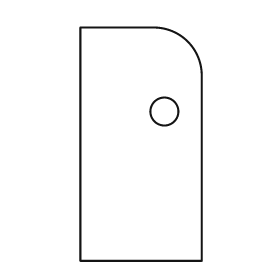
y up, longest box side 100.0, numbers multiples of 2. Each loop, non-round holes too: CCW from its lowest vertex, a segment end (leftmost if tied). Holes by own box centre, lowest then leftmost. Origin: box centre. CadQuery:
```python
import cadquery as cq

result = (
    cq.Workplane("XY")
    .moveTo(-26.0, -50.0)
    .lineTo(26.0, -50.0)
    .lineTo(26.0, 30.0)
    .threePointArc((20.0, 44.0), (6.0, 50.0))
    .lineTo(-26.0, 50.0)
    .close()
    .moveTo(10.0, 14.0)
    .circle(6.0)
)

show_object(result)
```